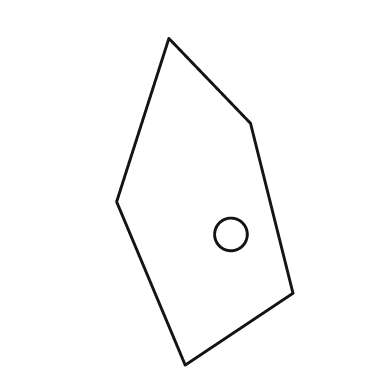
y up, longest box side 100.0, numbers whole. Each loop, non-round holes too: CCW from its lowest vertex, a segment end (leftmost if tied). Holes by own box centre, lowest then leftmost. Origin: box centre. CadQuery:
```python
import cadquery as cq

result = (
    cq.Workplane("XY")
    .moveTo(-6.0, -50.0)
    .lineTo(27.0, -28.0)
    .lineTo(14.0, 24.0)
    .lineTo(-11.0, 50.0)
    .lineTo(-27.0, 0.0)
    .close()
    .moveTo(8.0, -10.0)
    .circle(5.0)
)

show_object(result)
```